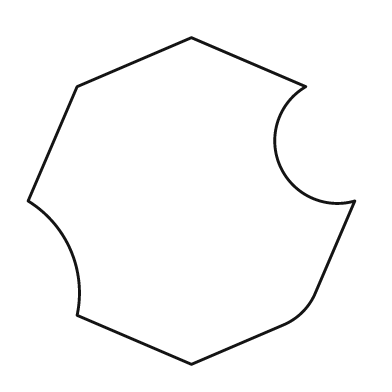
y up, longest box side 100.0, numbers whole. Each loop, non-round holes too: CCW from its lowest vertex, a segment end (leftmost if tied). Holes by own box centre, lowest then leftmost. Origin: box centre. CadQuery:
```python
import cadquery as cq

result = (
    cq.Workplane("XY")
    .moveTo(0.0, -50.0)
    .lineTo(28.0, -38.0)
    .threePointArc((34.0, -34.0), (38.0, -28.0))
    .lineTo(50.0, 0.0)
    .threePointArc((27.0, 11.0), (35.0, 35.0))
    .lineTo(0.0, 50.0)
    .lineTo(-35.0, 35.0)
    .lineTo(-50.0, 0.0)
    .threePointArc((-37.0, -15.0), (-35.0, -35.0))
    .close()
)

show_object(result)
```